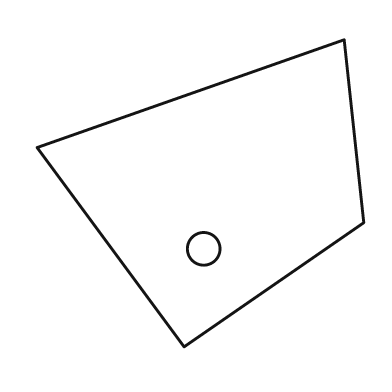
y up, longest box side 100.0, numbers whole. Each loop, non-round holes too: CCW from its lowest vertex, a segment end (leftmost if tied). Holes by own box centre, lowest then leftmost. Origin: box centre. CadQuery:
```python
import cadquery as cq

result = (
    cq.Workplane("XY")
    .moveTo(-5.0, -47.0)
    .lineTo(50.0, -9.0)
    .lineTo(44.0, 47.0)
    .lineTo(-50.0, 14.0)
    .close()
    .moveTo(1.0, -17.0)
    .circle(5.0)
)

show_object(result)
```